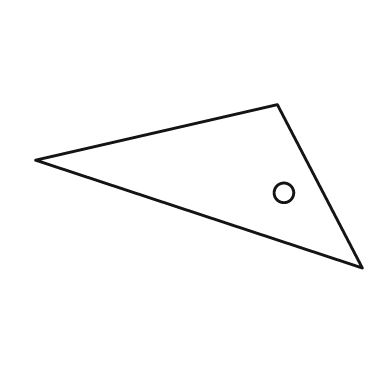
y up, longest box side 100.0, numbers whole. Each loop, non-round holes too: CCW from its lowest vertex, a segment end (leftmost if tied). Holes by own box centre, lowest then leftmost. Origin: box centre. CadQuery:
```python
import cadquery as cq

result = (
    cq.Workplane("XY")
    .moveTo(50.0, -25.0)
    .lineTo(24.0, 25.0)
    .lineTo(-50.0, 8.0)
    .close()
    .moveTo(26.0, -2.0)
    .circle(3.0)
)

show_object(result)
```